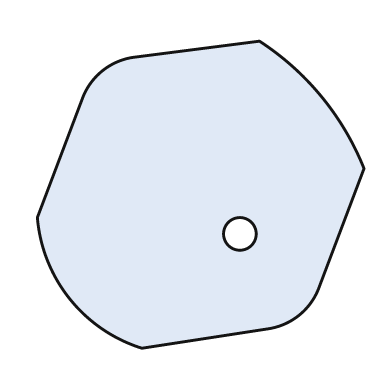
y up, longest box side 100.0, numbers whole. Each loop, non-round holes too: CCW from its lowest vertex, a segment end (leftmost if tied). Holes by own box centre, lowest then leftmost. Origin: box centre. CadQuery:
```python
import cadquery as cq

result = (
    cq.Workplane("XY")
    .moveTo(-18.0, -47.0)
    .lineTo(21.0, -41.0)
    .threePointArc((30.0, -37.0), (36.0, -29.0))
    .lineTo(50.0, 8.0)
    .threePointArc((37.0, 30.0), (18.0, 47.0))
    .lineTo(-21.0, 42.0)
    .threePointArc((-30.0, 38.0), (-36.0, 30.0))
    .lineTo(-50.0, -7.0)
    .threePointArc((-40.0, -32.0), (-18.0, -47.0))
    .close()
    .moveTo(12.0, -12.0)
    .circle(5.0)
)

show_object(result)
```